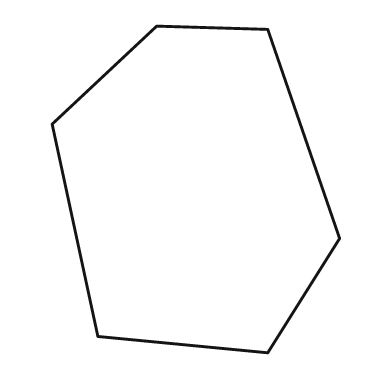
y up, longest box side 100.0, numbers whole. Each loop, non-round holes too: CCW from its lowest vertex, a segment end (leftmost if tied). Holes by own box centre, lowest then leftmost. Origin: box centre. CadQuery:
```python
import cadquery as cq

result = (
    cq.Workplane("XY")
    .moveTo(22.0, -50.0)
    .lineTo(44.0, -15.0)
    .lineTo(22.0, 49.0)
    .lineTo(-12.0, 50.0)
    .lineTo(-44.0, 20.0)
    .lineTo(-30.0, -45.0)
    .close()
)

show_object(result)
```